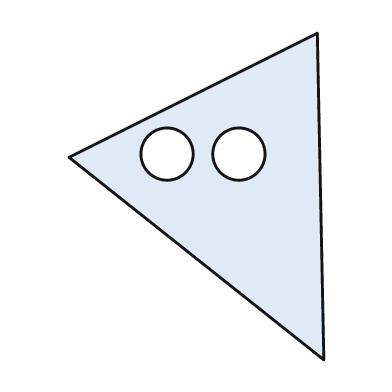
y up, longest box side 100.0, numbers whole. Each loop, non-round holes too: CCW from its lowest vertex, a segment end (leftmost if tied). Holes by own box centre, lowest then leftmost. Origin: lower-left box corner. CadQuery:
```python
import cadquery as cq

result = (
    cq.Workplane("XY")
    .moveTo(78.0, 0.0)
    .lineTo(76.0, 100.0)
    .lineTo(0.0, 62.0)
    .close()
    .moveTo(30.0, 63.0)
    .circle(8.0)
    .moveTo(52.0, 63.0)
    .circle(8.0)
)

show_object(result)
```